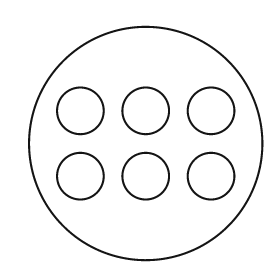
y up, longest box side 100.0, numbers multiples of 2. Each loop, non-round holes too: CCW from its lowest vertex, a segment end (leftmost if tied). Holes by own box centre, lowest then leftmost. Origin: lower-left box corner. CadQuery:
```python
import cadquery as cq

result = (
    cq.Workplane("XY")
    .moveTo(50.0, 50.0)
    .circle(50.0)
    .moveTo(22.0, 36.0)
    .circle(10.0)
    .moveTo(50.0, 36.0)
    .circle(10.0)
    .moveTo(78.0, 36.0)
    .circle(10.0)
    .moveTo(22.0, 64.0)
    .circle(10.0)
    .moveTo(50.0, 64.0)
    .circle(10.0)
    .moveTo(78.0, 64.0)
    .circle(10.0)
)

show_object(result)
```